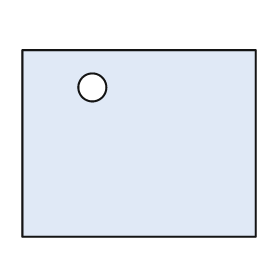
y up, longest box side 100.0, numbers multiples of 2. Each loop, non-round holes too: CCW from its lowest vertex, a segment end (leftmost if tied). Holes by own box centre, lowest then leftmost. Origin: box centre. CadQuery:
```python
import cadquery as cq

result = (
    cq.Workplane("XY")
    .moveTo(-50.0, -40.0)
    .lineTo(50.0, -40.0)
    .lineTo(50.0, 40.0)
    .lineTo(-50.0, 40.0)
    .close()
    .moveTo(-20.0, 24.0)
    .circle(6.0)
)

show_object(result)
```